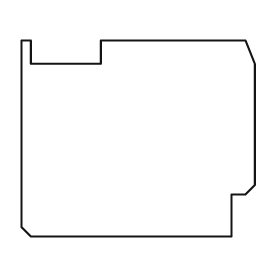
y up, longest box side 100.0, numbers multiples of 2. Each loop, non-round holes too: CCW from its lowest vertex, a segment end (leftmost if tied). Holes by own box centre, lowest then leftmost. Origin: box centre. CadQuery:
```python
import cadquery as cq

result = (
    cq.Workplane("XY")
    .moveTo(-46.0, -42.0)
    .lineTo(40.0, -42.0)
    .lineTo(40.0, -24.0)
    .lineTo(46.0, -24.0)
    .lineTo(50.0, -20.0)
    .lineTo(50.0, 32.0)
    .lineTo(46.0, 42.0)
    .lineTo(-16.0, 42.0)
    .lineTo(-16.0, 32.0)
    .lineTo(-46.0, 32.0)
    .lineTo(-46.0, 42.0)
    .lineTo(-50.0, 42.0)
    .lineTo(-50.0, -38.0)
    .close()
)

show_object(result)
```